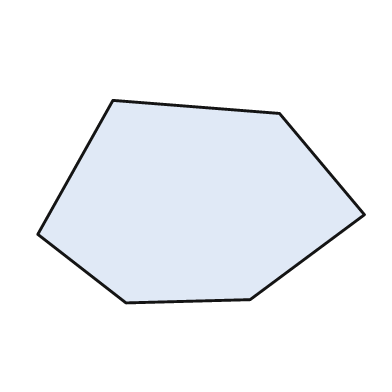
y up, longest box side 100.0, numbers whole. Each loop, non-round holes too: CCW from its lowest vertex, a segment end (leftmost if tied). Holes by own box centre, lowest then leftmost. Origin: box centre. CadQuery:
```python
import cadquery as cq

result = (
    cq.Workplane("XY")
    .moveTo(-23.0, -31.0)
    .lineTo(15.0, -30.0)
    .lineTo(50.0, -4.0)
    .lineTo(24.0, 27.0)
    .lineTo(-27.0, 31.0)
    .lineTo(-50.0, -10.0)
    .close()
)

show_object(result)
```